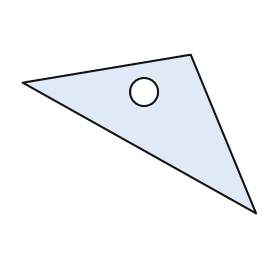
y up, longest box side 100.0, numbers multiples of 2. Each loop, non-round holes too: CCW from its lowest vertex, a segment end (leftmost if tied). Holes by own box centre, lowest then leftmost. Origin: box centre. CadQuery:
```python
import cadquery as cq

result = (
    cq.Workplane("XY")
    .moveTo(50.0, -34.0)
    .lineTo(22.0, 34.0)
    .lineTo(-50.0, 22.0)
    .close()
    .moveTo(2.0, 18.0)
    .circle(6.0)
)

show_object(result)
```